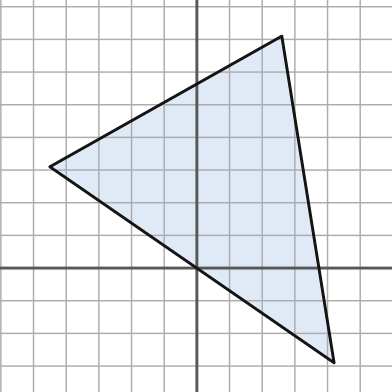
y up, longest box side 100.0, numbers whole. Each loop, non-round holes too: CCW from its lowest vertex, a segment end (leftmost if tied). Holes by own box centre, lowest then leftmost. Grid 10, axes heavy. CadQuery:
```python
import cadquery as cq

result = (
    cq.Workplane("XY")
    .moveTo(42.0, -29.0)
    .lineTo(26.0, 71.0)
    .lineTo(-45.0, 31.0)
    .close()
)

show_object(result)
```